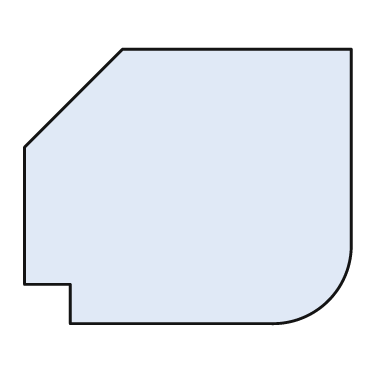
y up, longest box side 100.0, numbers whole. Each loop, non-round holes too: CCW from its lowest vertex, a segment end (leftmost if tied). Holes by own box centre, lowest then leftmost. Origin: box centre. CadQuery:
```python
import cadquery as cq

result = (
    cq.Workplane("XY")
    .moveTo(-36.0, -42.0)
    .lineTo(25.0, -42.0)
    .threePointArc((43.0, -35.0), (50.0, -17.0))
    .lineTo(50.0, 42.0)
    .lineTo(-20.0, 42.0)
    .lineTo(-50.0, 12.0)
    .lineTo(-50.0, -30.0)
    .lineTo(-36.0, -30.0)
    .close()
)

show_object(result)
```